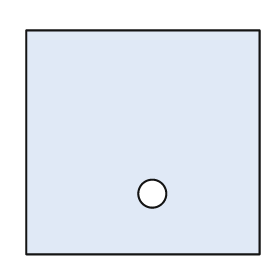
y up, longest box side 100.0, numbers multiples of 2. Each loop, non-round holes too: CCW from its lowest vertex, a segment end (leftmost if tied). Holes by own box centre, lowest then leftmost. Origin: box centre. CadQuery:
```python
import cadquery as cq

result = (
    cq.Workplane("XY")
    .moveTo(-50.0, -48.0)
    .lineTo(50.0, -48.0)
    .lineTo(50.0, 48.0)
    .lineTo(-50.0, 48.0)
    .close()
    .moveTo(4.0, -22.0)
    .circle(6.0)
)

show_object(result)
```